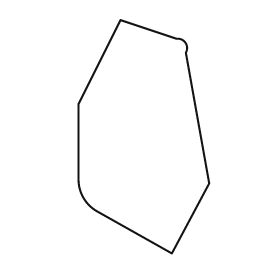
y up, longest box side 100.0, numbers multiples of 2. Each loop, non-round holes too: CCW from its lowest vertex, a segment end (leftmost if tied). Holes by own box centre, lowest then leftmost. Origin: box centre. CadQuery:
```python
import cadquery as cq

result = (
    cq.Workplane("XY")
    .moveTo(12.0, -50.0)
    .lineTo(28.0, -20.0)
    .lineTo(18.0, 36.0)
    .threePointArc((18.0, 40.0), (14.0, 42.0))
    .lineTo(-10.0, 50.0)
    .lineTo(-28.0, 14.0)
    .lineTo(-28.0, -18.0)
    .threePointArc((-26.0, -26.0), (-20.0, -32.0))
    .close()
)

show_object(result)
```